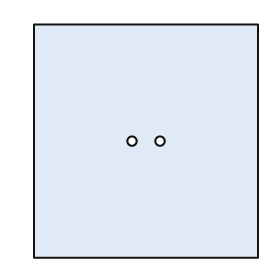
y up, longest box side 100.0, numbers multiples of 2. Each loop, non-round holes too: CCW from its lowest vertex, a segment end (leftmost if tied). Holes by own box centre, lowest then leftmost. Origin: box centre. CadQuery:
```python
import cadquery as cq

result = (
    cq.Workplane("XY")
    .moveTo(-48.0, -50.0)
    .lineTo(48.0, -50.0)
    .lineTo(48.0, 50.0)
    .lineTo(-48.0, 50.0)
    .close()
    .moveTo(-6.0, 0.0)
    .circle(2.0)
    .moveTo(6.0, 0.0)
    .circle(2.0)
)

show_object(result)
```